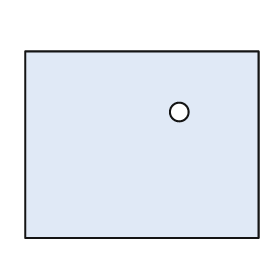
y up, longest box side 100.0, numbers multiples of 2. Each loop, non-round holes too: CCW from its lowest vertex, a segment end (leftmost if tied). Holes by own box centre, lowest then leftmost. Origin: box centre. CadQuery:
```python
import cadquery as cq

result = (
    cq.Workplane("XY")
    .moveTo(-50.0, -40.0)
    .lineTo(50.0, -40.0)
    .lineTo(50.0, 40.0)
    .lineTo(-50.0, 40.0)
    .close()
    .moveTo(16.0, 14.0)
    .circle(4.0)
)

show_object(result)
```